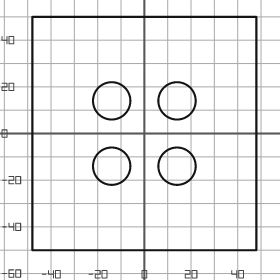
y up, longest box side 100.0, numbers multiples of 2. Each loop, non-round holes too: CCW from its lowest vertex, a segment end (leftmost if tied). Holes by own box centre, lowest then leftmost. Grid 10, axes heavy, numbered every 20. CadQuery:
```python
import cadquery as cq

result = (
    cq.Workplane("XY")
    .moveTo(-48.0, -50.0)
    .lineTo(48.0, -50.0)
    .lineTo(48.0, 50.0)
    .lineTo(-48.0, 50.0)
    .close()
    .moveTo(-14.0, -14.0)
    .circle(8.0)
    .moveTo(14.0, -14.0)
    .circle(8.0)
    .moveTo(-14.0, 14.0)
    .circle(8.0)
    .moveTo(14.0, 14.0)
    .circle(8.0)
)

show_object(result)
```